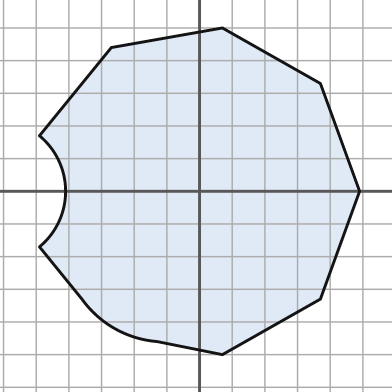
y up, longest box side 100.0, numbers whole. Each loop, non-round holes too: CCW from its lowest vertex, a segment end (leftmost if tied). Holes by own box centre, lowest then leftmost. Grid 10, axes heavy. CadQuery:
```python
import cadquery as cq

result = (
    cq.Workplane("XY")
    .moveTo(7.0, -50.0)
    .lineTo(37.0, -33.0)
    .lineTo(49.0, 0.0)
    .lineTo(37.0, 33.0)
    .lineTo(7.0, 50.0)
    .lineTo(-27.0, 44.0)
    .lineTo(-49.0, 17.0)
    .threePointArc((-41.0, 0.0), (-49.0, -17.0))
    .lineTo(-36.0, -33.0)
    .threePointArc((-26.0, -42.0), (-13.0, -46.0))
    .close()
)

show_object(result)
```